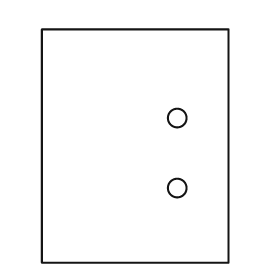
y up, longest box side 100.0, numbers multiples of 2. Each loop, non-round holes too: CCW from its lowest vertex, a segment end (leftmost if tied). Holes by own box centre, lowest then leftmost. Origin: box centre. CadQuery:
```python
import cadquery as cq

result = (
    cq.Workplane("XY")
    .moveTo(-40.0, -50.0)
    .lineTo(40.0, -50.0)
    .lineTo(40.0, 50.0)
    .lineTo(-40.0, 50.0)
    .close()
    .moveTo(18.0, -18.0)
    .circle(4.0)
    .moveTo(18.0, 12.0)
    .circle(4.0)
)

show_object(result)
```